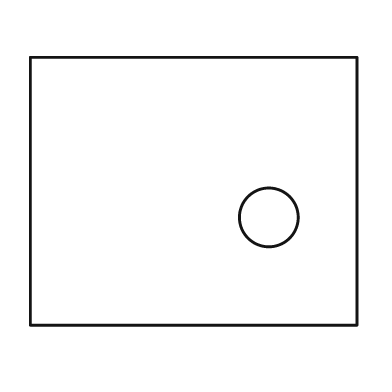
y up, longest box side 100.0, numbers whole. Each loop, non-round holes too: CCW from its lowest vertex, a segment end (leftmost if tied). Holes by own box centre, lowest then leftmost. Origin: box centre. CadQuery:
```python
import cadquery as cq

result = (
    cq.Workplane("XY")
    .moveTo(-50.0, -41.0)
    .lineTo(50.0, -41.0)
    .lineTo(50.0, 41.0)
    .lineTo(-50.0, 41.0)
    .close()
    .moveTo(23.0, -8.0)
    .circle(9.0)
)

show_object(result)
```